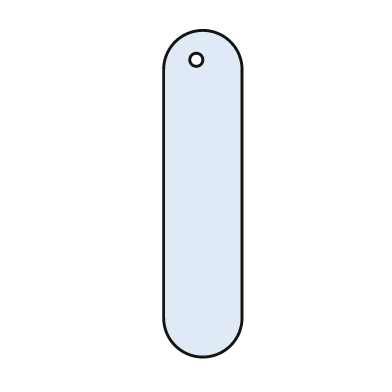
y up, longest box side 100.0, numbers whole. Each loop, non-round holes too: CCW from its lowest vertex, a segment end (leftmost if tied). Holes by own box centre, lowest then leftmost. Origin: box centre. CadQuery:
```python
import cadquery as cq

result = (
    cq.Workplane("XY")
    .moveTo(-12.0, -38.0)
    .threePointArc((0.0, -50.0), (12.0, -38.0))
    .lineTo(12.0, 38.0)
    .threePointArc((0.0, 50.0), (-12.0, 38.0))
    .close()
    .moveTo(-2.0, 41.0)
    .circle(2.0)
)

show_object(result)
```